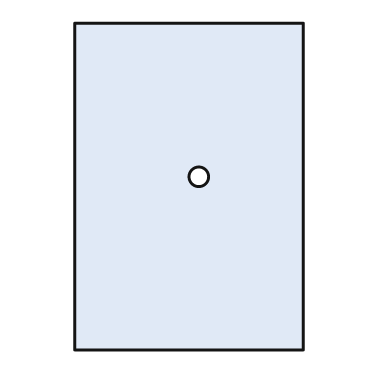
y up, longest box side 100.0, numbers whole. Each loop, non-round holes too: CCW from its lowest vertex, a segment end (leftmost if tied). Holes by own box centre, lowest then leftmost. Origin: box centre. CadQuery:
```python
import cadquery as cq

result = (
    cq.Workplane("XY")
    .moveTo(-35.0, -50.0)
    .lineTo(35.0, -50.0)
    .lineTo(35.0, 50.0)
    .lineTo(-35.0, 50.0)
    .close()
    .moveTo(3.0, 3.0)
    .circle(3.0)
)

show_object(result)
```